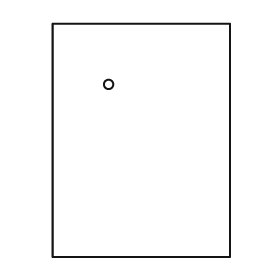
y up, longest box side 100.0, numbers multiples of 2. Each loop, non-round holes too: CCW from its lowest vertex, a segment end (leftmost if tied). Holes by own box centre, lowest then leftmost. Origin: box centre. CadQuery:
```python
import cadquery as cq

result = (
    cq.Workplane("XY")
    .moveTo(-38.0, -50.0)
    .lineTo(38.0, -50.0)
    .lineTo(38.0, 50.0)
    .lineTo(-38.0, 50.0)
    .close()
    .moveTo(-14.0, 24.0)
    .circle(2.0)
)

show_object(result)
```